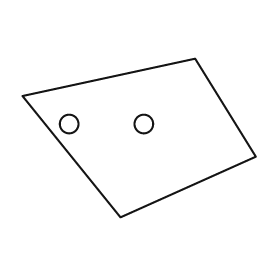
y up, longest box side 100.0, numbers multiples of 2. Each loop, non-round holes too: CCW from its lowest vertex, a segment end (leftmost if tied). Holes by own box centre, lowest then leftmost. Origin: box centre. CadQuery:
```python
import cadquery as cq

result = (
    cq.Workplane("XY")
    .moveTo(-8.0, -34.0)
    .lineTo(50.0, -8.0)
    .lineTo(24.0, 34.0)
    .lineTo(-50.0, 18.0)
    .close()
    .moveTo(-30.0, 6.0)
    .circle(4.0)
    .moveTo(2.0, 6.0)
    .circle(4.0)
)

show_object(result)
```